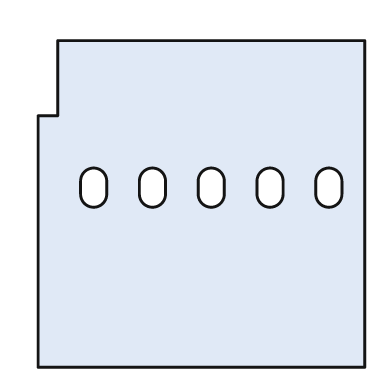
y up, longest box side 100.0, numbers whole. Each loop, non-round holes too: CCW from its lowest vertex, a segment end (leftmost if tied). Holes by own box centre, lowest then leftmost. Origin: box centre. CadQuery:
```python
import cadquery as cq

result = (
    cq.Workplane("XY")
    .moveTo(-50.0, -50.0)
    .lineTo(50.0, -50.0)
    .lineTo(50.0, 50.0)
    .lineTo(-44.0, 50.0)
    .lineTo(-44.0, 27.0)
    .lineTo(-50.0, 27.0)
    .close()
    .moveTo(-37.0, 3.0)
    .threePointArc((-33.0, -1.0), (-29.0, 3.0))
    .lineTo(-29.0, 7.0)
    .threePointArc((-33.0, 11.0), (-37.0, 7.0))
    .close()
    .moveTo(-19.0, 3.0)
    .threePointArc((-15.0, -1.0), (-11.0, 3.0))
    .lineTo(-11.0, 7.0)
    .threePointArc((-15.0, 11.0), (-19.0, 7.0))
    .close()
    .moveTo(-1.0, 3.0)
    .threePointArc((3.0, -1.0), (7.0, 3.0))
    .lineTo(7.0, 7.0)
    .threePointArc((3.0, 11.0), (-1.0, 7.0))
    .close()
    .moveTo(17.0, 3.0)
    .threePointArc((21.0, -1.0), (25.0, 3.0))
    .lineTo(25.0, 7.0)
    .threePointArc((21.0, 11.0), (17.0, 7.0))
    .close()
    .moveTo(35.0, 3.0)
    .threePointArc((39.0, -1.0), (43.0, 3.0))
    .lineTo(43.0, 7.0)
    .threePointArc((39.0, 11.0), (35.0, 7.0))
    .close()
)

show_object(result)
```